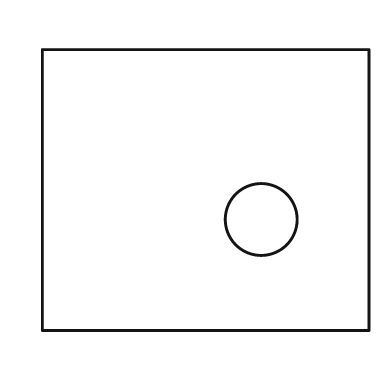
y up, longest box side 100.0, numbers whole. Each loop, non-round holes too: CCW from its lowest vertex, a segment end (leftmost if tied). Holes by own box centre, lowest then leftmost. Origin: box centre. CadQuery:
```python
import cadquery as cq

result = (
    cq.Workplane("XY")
    .moveTo(-50.0, -43.0)
    .lineTo(50.0, -43.0)
    .lineTo(50.0, 43.0)
    .lineTo(-50.0, 43.0)
    .close()
    .moveTo(17.0, -9.0)
    .circle(11.0)
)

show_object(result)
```